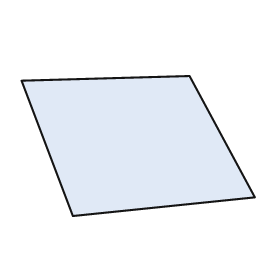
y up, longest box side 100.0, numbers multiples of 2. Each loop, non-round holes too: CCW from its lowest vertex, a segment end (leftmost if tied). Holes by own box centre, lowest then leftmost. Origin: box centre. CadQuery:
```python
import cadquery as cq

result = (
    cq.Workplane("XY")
    .moveTo(-28.0, -30.0)
    .lineTo(50.0, -22.0)
    .lineTo(22.0, 30.0)
    .lineTo(-50.0, 28.0)
    .close()
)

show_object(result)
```